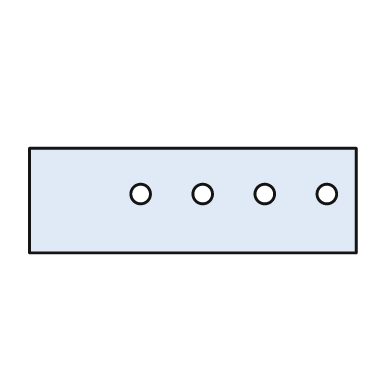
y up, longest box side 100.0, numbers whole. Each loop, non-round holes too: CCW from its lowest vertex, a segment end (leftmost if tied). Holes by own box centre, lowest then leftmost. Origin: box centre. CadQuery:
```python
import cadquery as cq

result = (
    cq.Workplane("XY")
    .moveTo(-50.0, -16.0)
    .lineTo(50.0, -16.0)
    .lineTo(50.0, 16.0)
    .lineTo(-50.0, 16.0)
    .close()
    .moveTo(-16.0, 2.0)
    .circle(3.0)
    .moveTo(3.0, 2.0)
    .circle(3.0)
    .moveTo(22.0, 2.0)
    .circle(3.0)
    .moveTo(41.0, 2.0)
    .circle(3.0)
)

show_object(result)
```